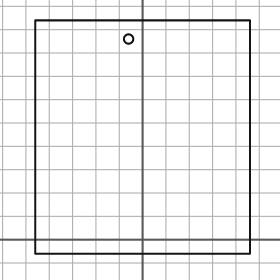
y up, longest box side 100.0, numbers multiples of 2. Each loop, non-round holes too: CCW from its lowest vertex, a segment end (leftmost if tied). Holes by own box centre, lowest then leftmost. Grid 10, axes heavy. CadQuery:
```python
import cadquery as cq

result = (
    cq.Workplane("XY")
    .moveTo(-46.0, -6.0)
    .lineTo(46.0, -6.0)
    .lineTo(46.0, 94.0)
    .lineTo(-46.0, 94.0)
    .close()
    .moveTo(-6.0, 86.0)
    .circle(2.0)
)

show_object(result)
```